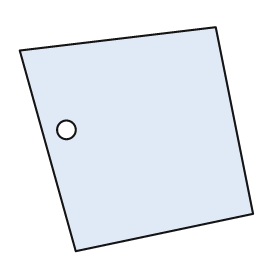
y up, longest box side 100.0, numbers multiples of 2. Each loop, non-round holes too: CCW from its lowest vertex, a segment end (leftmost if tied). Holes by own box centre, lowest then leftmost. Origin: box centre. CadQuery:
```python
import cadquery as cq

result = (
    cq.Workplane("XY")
    .moveTo(-26.0, -48.0)
    .lineTo(50.0, -32.0)
    .lineTo(34.0, 48.0)
    .lineTo(-50.0, 38.0)
    .close()
    .moveTo(-30.0, 4.0)
    .circle(4.0)
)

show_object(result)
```